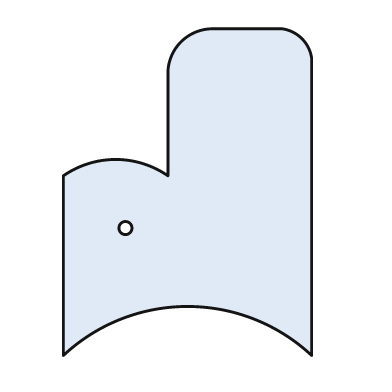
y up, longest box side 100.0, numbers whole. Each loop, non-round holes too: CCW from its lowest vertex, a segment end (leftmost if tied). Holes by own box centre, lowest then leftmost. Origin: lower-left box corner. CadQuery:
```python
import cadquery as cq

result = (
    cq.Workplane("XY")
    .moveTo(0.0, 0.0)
    .threePointArc((38.0, 15.0), (76.0, 0.0))
    .lineTo(76.0, 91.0)
    .threePointArc((73.0, 97.0), (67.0, 100.0))
    .lineTo(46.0, 100.0)
    .threePointArc((36.0, 96.0), (32.0, 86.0))
    .lineTo(32.0, 55.0)
    .threePointArc((16.0, 60.0), (0.0, 55.0))
    .close()
    .moveTo(19.0, 39.0)
    .circle(2.0)
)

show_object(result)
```